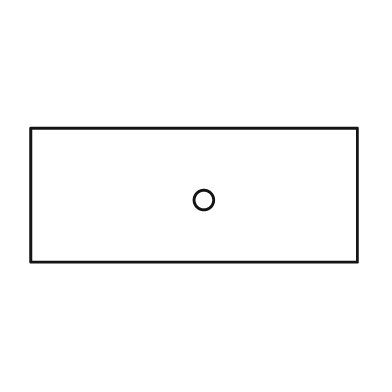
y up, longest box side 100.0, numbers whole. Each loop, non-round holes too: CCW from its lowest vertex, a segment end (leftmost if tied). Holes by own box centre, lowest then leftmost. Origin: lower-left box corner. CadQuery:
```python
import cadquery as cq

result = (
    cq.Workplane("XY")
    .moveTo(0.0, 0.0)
    .lineTo(100.0, 0.0)
    .lineTo(100.0, 41.0)
    .lineTo(0.0, 41.0)
    .close()
    .moveTo(53.0, 19.0)
    .circle(3.0)
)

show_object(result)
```